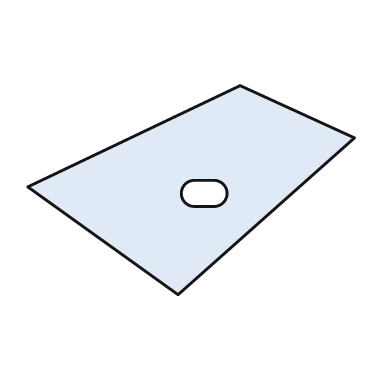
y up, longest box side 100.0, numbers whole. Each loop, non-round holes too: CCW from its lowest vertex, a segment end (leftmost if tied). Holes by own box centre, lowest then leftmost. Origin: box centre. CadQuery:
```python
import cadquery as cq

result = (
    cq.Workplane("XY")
    .moveTo(-4.0, -32.0)
    .lineTo(50.0, 16.0)
    .lineTo(15.0, 32.0)
    .lineTo(-50.0, 1.0)
    .close()
    .moveTo(1.0, -5.0)
    .lineTo(7.0, -5.0)
    .threePointArc((11.0, -1.0), (7.0, 3.0))
    .lineTo(1.0, 3.0)
    .threePointArc((-3.0, -1.0), (1.0, -5.0))
    .close()
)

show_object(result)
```